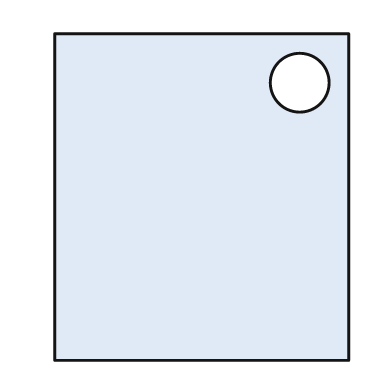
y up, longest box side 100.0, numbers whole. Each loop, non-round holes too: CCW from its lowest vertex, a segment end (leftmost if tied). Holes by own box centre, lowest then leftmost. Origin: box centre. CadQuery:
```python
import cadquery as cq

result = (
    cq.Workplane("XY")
    .moveTo(-45.0, -50.0)
    .lineTo(45.0, -50.0)
    .lineTo(45.0, 50.0)
    .lineTo(-45.0, 50.0)
    .close()
    .moveTo(30.0, 35.0)
    .circle(9.0)
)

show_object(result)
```